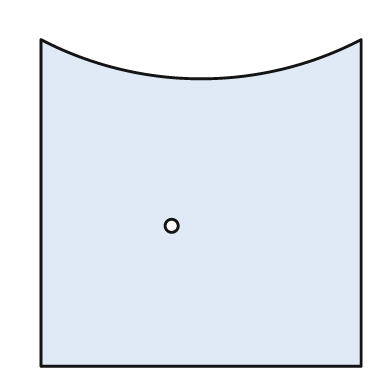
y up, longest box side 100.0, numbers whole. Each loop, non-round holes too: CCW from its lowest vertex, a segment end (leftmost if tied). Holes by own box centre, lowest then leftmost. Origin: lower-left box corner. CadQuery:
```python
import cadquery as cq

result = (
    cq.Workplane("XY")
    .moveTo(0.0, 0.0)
    .lineTo(98.0, 0.0)
    .lineTo(98.0, 100.0)
    .threePointArc((49.0, 88.0), (0.0, 100.0))
    .close()
    .moveTo(40.0, 43.0)
    .circle(2.0)
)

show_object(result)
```